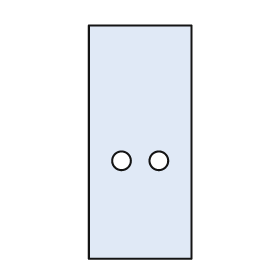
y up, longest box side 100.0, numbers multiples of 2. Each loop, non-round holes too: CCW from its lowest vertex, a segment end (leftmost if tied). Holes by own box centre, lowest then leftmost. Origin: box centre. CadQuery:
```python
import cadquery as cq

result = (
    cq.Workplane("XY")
    .moveTo(-22.0, -50.0)
    .lineTo(22.0, -50.0)
    .lineTo(22.0, 50.0)
    .lineTo(-22.0, 50.0)
    .close()
    .moveTo(-8.0, -8.0)
    .circle(4.0)
    .moveTo(8.0, -8.0)
    .circle(4.0)
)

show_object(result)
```